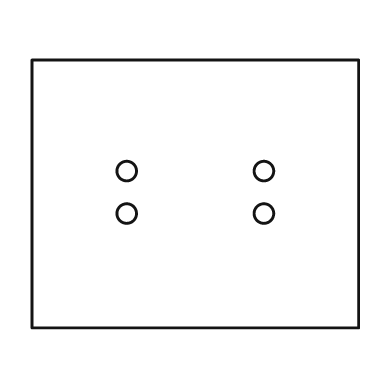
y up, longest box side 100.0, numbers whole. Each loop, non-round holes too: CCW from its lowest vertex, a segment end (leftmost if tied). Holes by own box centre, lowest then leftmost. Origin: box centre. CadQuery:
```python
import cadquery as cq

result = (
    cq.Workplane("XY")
    .moveTo(-50.0, -41.0)
    .lineTo(50.0, -41.0)
    .lineTo(50.0, 41.0)
    .lineTo(-50.0, 41.0)
    .close()
    .moveTo(-21.0, -6.0)
    .circle(3.0)
    .moveTo(21.0, -6.0)
    .circle(3.0)
    .moveTo(-21.0, 7.0)
    .circle(3.0)
    .moveTo(21.0, 7.0)
    .circle(3.0)
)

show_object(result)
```